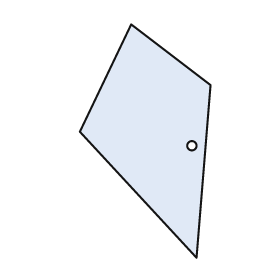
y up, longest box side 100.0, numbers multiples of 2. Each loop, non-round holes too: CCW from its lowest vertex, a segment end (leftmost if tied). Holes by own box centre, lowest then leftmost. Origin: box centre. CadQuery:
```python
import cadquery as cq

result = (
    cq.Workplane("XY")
    .moveTo(22.0, -50.0)
    .lineTo(28.0, 24.0)
    .lineTo(-6.0, 50.0)
    .lineTo(-28.0, 4.0)
    .close()
    .moveTo(20.0, -2.0)
    .circle(2.0)
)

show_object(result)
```